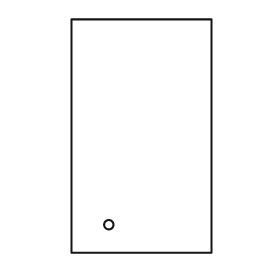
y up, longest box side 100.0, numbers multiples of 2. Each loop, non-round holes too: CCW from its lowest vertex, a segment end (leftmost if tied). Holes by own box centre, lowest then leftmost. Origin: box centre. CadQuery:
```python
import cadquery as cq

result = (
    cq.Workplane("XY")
    .moveTo(-30.0, -50.0)
    .lineTo(30.0, -50.0)
    .lineTo(30.0, 50.0)
    .lineTo(-30.0, 50.0)
    .close()
    .moveTo(-14.0, -38.0)
    .circle(2.0)
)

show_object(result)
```